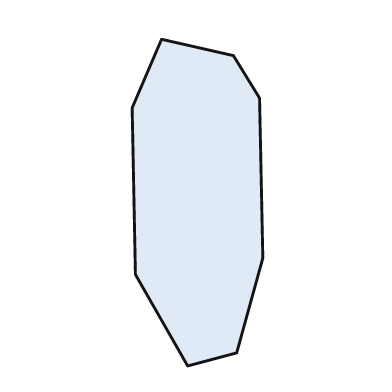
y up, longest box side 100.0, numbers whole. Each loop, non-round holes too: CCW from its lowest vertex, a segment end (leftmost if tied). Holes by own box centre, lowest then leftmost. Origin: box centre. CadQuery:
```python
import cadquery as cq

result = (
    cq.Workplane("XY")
    .moveTo(-3.0, -50.0)
    .lineTo(12.0, -46.0)
    .lineTo(20.0, -17.0)
    .lineTo(19.0, 32.0)
    .lineTo(11.0, 45.0)
    .lineTo(-11.0, 50.0)
    .lineTo(-20.0, 29.0)
    .lineTo(-19.0, -22.0)
    .close()
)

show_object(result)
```